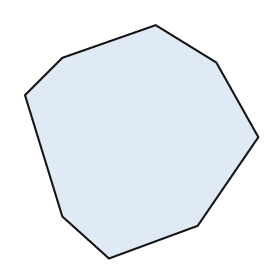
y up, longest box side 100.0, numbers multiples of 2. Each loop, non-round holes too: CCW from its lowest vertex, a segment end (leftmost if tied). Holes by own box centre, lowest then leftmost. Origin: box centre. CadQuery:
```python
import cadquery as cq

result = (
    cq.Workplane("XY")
    .moveTo(-14.0, -50.0)
    .lineTo(24.0, -36.0)
    .lineTo(50.0, 2.0)
    .lineTo(32.0, 34.0)
    .lineTo(6.0, 50.0)
    .lineTo(-34.0, 36.0)
    .lineTo(-50.0, 20.0)
    .lineTo(-34.0, -32.0)
    .close()
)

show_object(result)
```